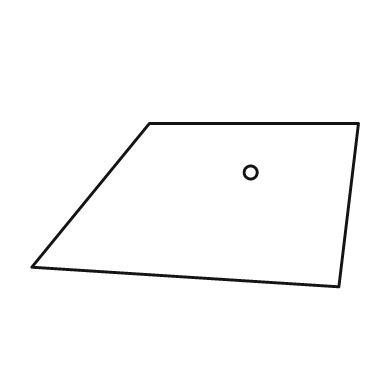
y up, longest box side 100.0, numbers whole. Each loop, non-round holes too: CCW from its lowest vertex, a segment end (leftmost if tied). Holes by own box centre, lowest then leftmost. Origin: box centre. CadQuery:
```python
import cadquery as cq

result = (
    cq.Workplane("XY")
    .moveTo(44.0, -25.0)
    .lineTo(50.0, 25.0)
    .lineTo(-14.0, 25.0)
    .lineTo(-50.0, -19.0)
    .close()
    .moveTo(17.0, 10.0)
    .circle(2.0)
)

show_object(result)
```